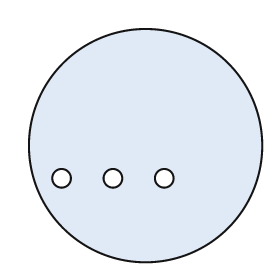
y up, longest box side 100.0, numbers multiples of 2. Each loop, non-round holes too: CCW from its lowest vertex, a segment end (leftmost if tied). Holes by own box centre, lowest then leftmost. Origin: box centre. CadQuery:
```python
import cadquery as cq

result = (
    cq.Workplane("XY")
    .moveTo(0.0, 0.0)
    .circle(50.0)
    .moveTo(-36.0, -14.0)
    .circle(4.0)
    .moveTo(-14.0, -14.0)
    .circle(4.0)
    .moveTo(8.0, -14.0)
    .circle(4.0)
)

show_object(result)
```